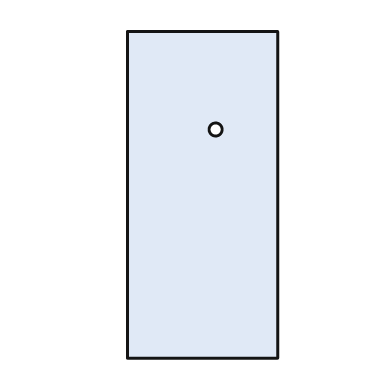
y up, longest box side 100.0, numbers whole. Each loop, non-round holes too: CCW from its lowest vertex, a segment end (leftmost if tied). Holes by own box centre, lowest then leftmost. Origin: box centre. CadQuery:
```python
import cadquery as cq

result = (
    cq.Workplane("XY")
    .moveTo(-23.0, -50.0)
    .lineTo(23.0, -50.0)
    .lineTo(23.0, 50.0)
    .lineTo(-23.0, 50.0)
    .close()
    .moveTo(4.0, 20.0)
    .circle(2.0)
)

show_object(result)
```